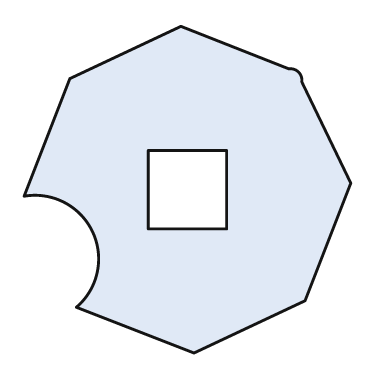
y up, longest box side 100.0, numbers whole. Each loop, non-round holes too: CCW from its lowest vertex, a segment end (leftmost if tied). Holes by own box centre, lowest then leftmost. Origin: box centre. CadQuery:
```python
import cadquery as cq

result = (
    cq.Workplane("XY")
    .moveTo(2.0, -50.0)
    .lineTo(36.0, -34.0)
    .lineTo(50.0, 2.0)
    .lineTo(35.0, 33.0)
    .threePointArc((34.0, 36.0), (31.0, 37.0))
    .lineTo(-2.0, 50.0)
    .lineTo(-36.0, 34.0)
    .lineTo(-50.0, -2.0)
    .threePointArc((-29.0, -13.0), (-34.0, -36.0))
    .close()
    .moveTo(-12.0, -12.0)
    .lineTo(12.0, -12.0)
    .lineTo(12.0, 12.0)
    .lineTo(-12.0, 12.0)
    .close()
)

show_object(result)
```